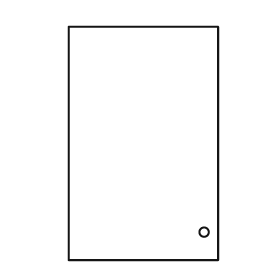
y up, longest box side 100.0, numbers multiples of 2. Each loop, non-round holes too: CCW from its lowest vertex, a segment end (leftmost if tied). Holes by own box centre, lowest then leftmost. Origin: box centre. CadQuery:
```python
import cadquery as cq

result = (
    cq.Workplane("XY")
    .moveTo(-32.0, -50.0)
    .lineTo(32.0, -50.0)
    .lineTo(32.0, 50.0)
    .lineTo(-32.0, 50.0)
    .close()
    .moveTo(26.0, -38.0)
    .circle(2.0)
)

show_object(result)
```